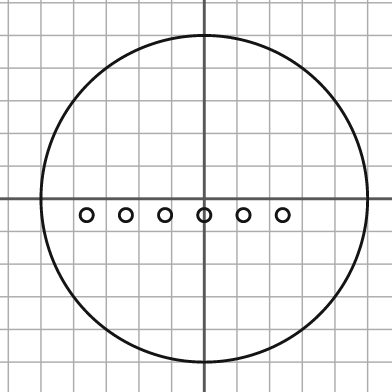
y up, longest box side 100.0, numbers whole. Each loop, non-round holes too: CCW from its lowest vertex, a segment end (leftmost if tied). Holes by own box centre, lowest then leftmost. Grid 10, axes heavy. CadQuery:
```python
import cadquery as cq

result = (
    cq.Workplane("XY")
    .moveTo(0.0, 0.0)
    .circle(50.0)
    .moveTo(-36.0, -5.0)
    .circle(2.0)
    .moveTo(-24.0, -5.0)
    .circle(2.0)
    .moveTo(-12.0, -5.0)
    .circle(2.0)
    .moveTo(0.0, -5.0)
    .circle(2.0)
    .moveTo(12.0, -5.0)
    .circle(2.0)
    .moveTo(24.0, -5.0)
    .circle(2.0)
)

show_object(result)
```